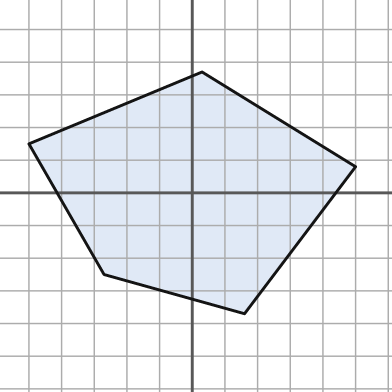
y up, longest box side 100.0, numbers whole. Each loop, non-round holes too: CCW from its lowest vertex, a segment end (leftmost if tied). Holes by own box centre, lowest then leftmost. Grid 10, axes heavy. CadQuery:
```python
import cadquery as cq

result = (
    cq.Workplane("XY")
    .moveTo(16.0, -37.0)
    .lineTo(50.0, 8.0)
    .lineTo(3.0, 37.0)
    .lineTo(-50.0, 15.0)
    .lineTo(-27.0, -25.0)
    .close()
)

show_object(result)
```